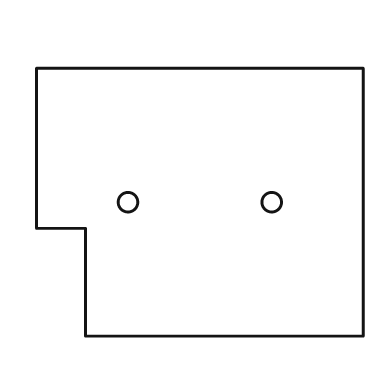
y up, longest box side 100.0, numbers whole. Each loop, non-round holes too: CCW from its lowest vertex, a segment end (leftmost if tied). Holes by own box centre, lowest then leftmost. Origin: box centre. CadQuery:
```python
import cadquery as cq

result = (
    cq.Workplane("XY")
    .moveTo(-35.0, -41.0)
    .lineTo(50.0, -41.0)
    .lineTo(50.0, 41.0)
    .lineTo(-50.0, 41.0)
    .lineTo(-50.0, -8.0)
    .lineTo(-35.0, -8.0)
    .close()
    .moveTo(-22.0, 0.0)
    .circle(3.0)
    .moveTo(22.0, 0.0)
    .circle(3.0)
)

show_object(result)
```